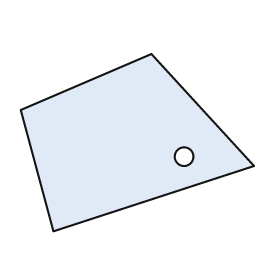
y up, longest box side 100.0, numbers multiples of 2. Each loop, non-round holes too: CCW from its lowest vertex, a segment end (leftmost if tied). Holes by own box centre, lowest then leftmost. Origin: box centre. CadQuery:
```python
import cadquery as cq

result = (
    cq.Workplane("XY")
    .moveTo(-36.0, -38.0)
    .lineTo(50.0, -10.0)
    .lineTo(6.0, 38.0)
    .lineTo(-50.0, 14.0)
    .close()
    .moveTo(20.0, -6.0)
    .circle(4.0)
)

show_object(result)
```